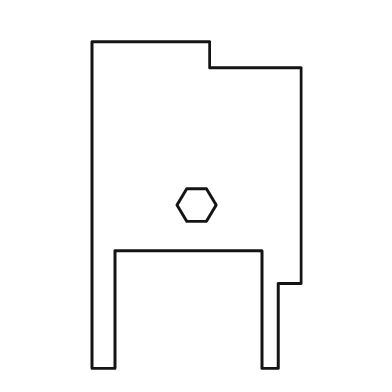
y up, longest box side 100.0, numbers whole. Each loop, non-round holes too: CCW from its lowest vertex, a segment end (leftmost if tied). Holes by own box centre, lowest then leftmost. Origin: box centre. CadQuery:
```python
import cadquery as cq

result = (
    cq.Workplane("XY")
    .moveTo(-32.0, -50.0)
    .lineTo(-25.0, -50.0)
    .lineTo(-25.0, -14.0)
    .lineTo(20.0, -14.0)
    .lineTo(20.0, -50.0)
    .lineTo(25.0, -50.0)
    .lineTo(25.0, -24.0)
    .lineTo(32.0, -24.0)
    .lineTo(32.0, 42.0)
    .lineTo(4.0, 42.0)
    .lineTo(4.0, 50.0)
    .lineTo(-32.0, 50.0)
    .close()
    .moveTo(-3.0, -5.0)
    .lineTo(3.0, -5.0)
    .lineTo(6.0, 0.0)
    .lineTo(3.0, 5.0)
    .lineTo(-3.0, 5.0)
    .lineTo(-6.0, 0.0)
    .close()
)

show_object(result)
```